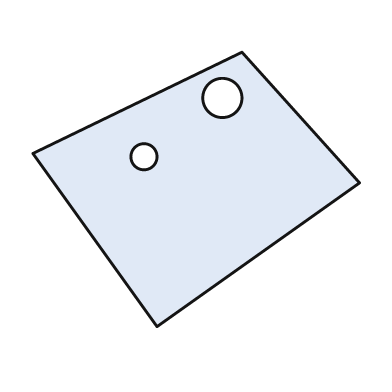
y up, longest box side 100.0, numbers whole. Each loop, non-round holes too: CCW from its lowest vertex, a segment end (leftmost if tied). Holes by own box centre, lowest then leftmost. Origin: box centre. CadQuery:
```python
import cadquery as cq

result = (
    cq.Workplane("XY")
    .moveTo(-12.0, -42.0)
    .lineTo(50.0, 2.0)
    .lineTo(14.0, 42.0)
    .lineTo(-50.0, 11.0)
    .close()
    .moveTo(-16.0, 10.0)
    .circle(4.0)
    .moveTo(8.0, 28.0)
    .circle(6.0)
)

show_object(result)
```